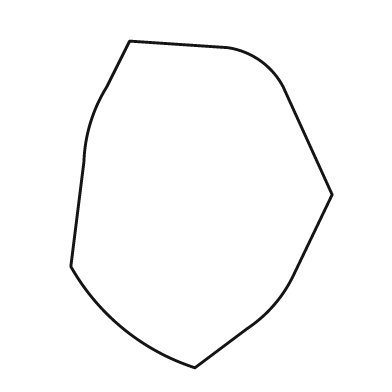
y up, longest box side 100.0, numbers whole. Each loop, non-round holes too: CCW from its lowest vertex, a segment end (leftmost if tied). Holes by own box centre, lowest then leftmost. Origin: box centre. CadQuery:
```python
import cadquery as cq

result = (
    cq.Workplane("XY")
    .moveTo(-2.0, -50.0)
    .lineTo(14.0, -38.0)
    .threePointArc((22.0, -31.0), (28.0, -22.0))
    .lineTo(40.0, 3.0)
    .lineTo(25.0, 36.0)
    .threePointArc((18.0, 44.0), (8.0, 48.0))
    .lineTo(-22.0, 50.0)
    .lineTo(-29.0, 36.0)
    .threePointArc((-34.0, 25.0), (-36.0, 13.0))
    .lineTo(-40.0, -19.0)
    .threePointArc((-24.0, -38.0), (-2.0, -50.0))
    .close()
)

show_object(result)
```